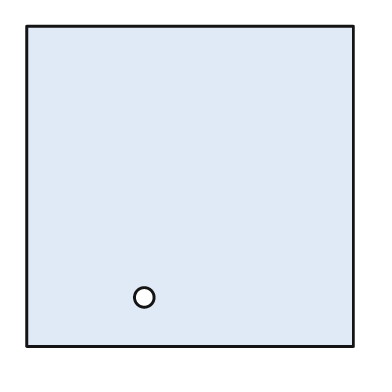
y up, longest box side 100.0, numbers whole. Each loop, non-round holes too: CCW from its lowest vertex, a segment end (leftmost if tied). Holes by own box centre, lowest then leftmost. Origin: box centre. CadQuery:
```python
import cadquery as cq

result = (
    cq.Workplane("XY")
    .moveTo(-50.0, -49.0)
    .lineTo(50.0, -49.0)
    .lineTo(50.0, 49.0)
    .lineTo(-50.0, 49.0)
    .close()
    .moveTo(-14.0, -34.0)
    .circle(3.0)
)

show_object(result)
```